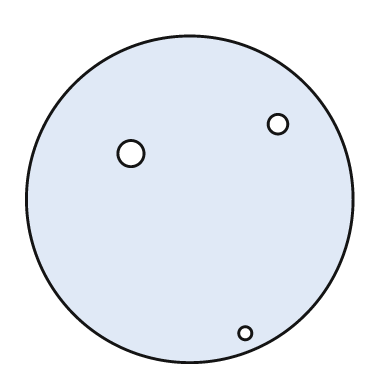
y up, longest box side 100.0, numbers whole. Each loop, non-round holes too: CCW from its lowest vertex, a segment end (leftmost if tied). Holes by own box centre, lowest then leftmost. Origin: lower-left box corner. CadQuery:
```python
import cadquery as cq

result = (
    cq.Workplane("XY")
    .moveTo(50.0, 50.0)
    .circle(50.0)
    .moveTo(67.0, 9.0)
    .circle(2.0)
    .moveTo(32.0, 64.0)
    .circle(4.0)
    .moveTo(77.0, 73.0)
    .circle(3.0)
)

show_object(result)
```